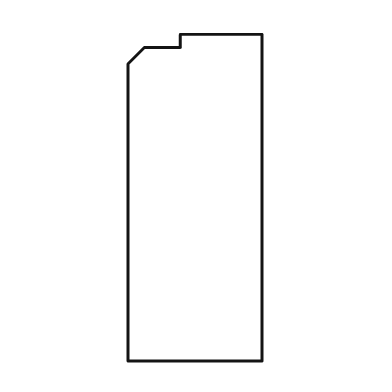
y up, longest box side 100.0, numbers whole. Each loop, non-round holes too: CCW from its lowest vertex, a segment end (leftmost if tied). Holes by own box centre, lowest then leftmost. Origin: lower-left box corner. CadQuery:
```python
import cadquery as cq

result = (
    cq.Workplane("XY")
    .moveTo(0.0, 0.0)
    .lineTo(41.0, 0.0)
    .lineTo(41.0, 100.0)
    .lineTo(16.0, 100.0)
    .lineTo(16.0, 96.0)
    .lineTo(5.0, 96.0)
    .lineTo(0.0, 91.0)
    .close()
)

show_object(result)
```